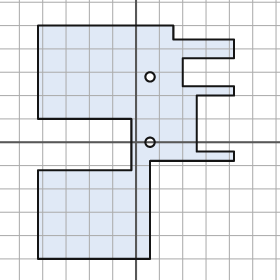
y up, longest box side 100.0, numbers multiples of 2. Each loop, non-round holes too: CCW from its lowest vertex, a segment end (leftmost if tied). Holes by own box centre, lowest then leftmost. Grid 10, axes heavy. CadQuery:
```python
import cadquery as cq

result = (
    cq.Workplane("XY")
    .moveTo(-42.0, -50.0)
    .lineTo(6.0, -50.0)
    .lineTo(6.0, -8.0)
    .lineTo(42.0, -8.0)
    .lineTo(42.0, -4.0)
    .lineTo(26.0, -4.0)
    .lineTo(26.0, 20.0)
    .lineTo(42.0, 20.0)
    .lineTo(42.0, 24.0)
    .lineTo(20.0, 24.0)
    .lineTo(20.0, 36.0)
    .lineTo(42.0, 36.0)
    .lineTo(42.0, 44.0)
    .lineTo(16.0, 44.0)
    .lineTo(16.0, 50.0)
    .lineTo(-42.0, 50.0)
    .lineTo(-42.0, 10.0)
    .lineTo(-2.0, 10.0)
    .lineTo(-2.0, -12.0)
    .lineTo(-42.0, -12.0)
    .close()
    .moveTo(6.0, 0.0)
    .circle(2.0)
    .moveTo(6.0, 28.0)
    .circle(2.0)
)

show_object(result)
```